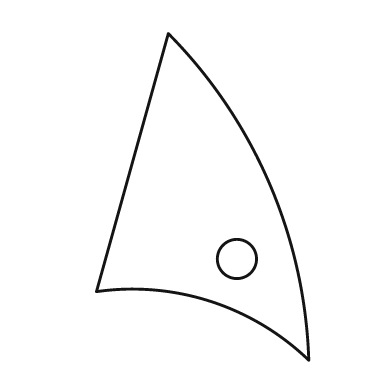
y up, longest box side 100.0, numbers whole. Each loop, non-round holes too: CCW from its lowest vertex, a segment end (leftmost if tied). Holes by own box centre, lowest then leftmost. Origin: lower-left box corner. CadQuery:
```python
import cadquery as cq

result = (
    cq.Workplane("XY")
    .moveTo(65.0, 0.0)
    .threePointArc((53.0, 54.0), (22.0, 100.0))
    .lineTo(0.0, 21.0)
    .threePointArc((35.0, 18.0), (65.0, 0.0))
    .close()
    .moveTo(43.0, 31.0)
    .circle(6.0)
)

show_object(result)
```